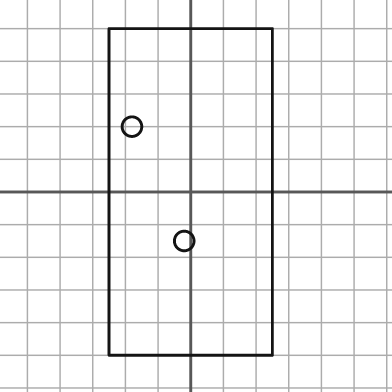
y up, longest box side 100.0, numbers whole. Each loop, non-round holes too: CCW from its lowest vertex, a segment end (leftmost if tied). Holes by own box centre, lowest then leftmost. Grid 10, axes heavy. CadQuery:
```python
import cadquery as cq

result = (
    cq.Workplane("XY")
    .moveTo(-25.0, -50.0)
    .lineTo(25.0, -50.0)
    .lineTo(25.0, 50.0)
    .lineTo(-25.0, 50.0)
    .close()
    .moveTo(-2.0, -15.0)
    .circle(3.0)
    .moveTo(-18.0, 20.0)
    .circle(3.0)
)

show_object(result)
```